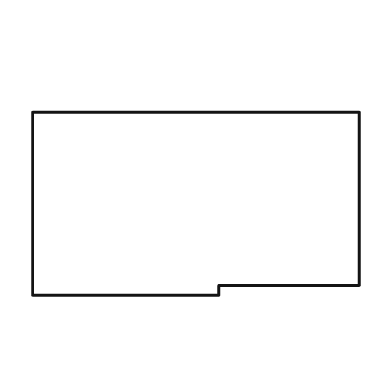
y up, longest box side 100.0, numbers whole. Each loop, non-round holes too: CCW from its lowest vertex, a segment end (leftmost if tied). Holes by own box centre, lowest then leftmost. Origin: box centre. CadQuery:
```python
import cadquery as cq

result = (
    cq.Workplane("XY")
    .moveTo(-50.0, -28.0)
    .lineTo(7.0, -28.0)
    .lineTo(7.0, -25.0)
    .lineTo(50.0, -25.0)
    .lineTo(50.0, 28.0)
    .lineTo(-50.0, 28.0)
    .close()
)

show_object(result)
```